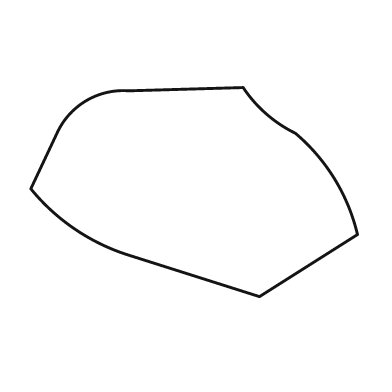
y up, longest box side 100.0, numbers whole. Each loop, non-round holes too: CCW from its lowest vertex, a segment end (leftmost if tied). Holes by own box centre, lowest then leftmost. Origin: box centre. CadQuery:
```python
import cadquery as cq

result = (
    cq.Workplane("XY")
    .moveTo(20.0, -32.0)
    .lineTo(50.0, -13.0)
    .threePointArc((43.0, 4.0), (31.0, 18.0))
    .threePointArc((22.0, 24.0), (15.0, 32.0))
    .lineTo(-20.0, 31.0)
    .threePointArc((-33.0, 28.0), (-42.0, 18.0))
    .lineTo(-50.0, 1.0)
    .threePointArc((-37.0, -11.0), (-21.0, -19.0))
    .close()
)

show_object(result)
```